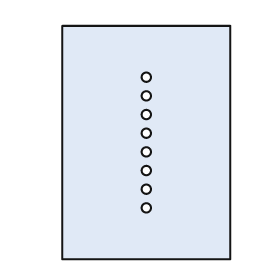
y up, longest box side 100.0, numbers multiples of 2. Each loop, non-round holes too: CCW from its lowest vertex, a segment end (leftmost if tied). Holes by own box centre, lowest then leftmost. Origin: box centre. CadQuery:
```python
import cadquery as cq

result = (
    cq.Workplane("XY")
    .moveTo(-36.0, -50.0)
    .lineTo(36.0, -50.0)
    .lineTo(36.0, 50.0)
    .lineTo(-36.0, 50.0)
    .close()
    .moveTo(0.0, -28.0)
    .circle(2.0)
    .moveTo(0.0, -20.0)
    .circle(2.0)
    .moveTo(0.0, -12.0)
    .circle(2.0)
    .moveTo(0.0, -4.0)
    .circle(2.0)
    .moveTo(0.0, 4.0)
    .circle(2.0)
    .moveTo(0.0, 12.0)
    .circle(2.0)
    .moveTo(0.0, 20.0)
    .circle(2.0)
    .moveTo(0.0, 28.0)
    .circle(2.0)
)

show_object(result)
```